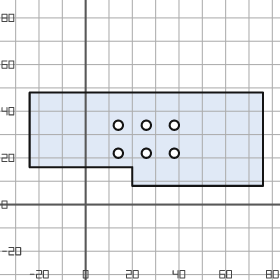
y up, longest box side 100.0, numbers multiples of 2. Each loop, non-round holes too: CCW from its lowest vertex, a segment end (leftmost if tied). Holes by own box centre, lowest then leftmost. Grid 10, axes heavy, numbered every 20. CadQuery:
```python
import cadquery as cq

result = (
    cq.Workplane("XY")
    .moveTo(20.0, 8.0)
    .lineTo(76.0, 8.0)
    .lineTo(76.0, 48.0)
    .lineTo(-24.0, 48.0)
    .lineTo(-24.0, 16.0)
    .lineTo(20.0, 16.0)
    .close()
    .moveTo(14.0, 22.0)
    .circle(2.0)
    .moveTo(26.0, 22.0)
    .circle(2.0)
    .moveTo(38.0, 22.0)
    .circle(2.0)
    .moveTo(14.0, 34.0)
    .circle(2.0)
    .moveTo(26.0, 34.0)
    .circle(2.0)
    .moveTo(38.0, 34.0)
    .circle(2.0)
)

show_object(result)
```